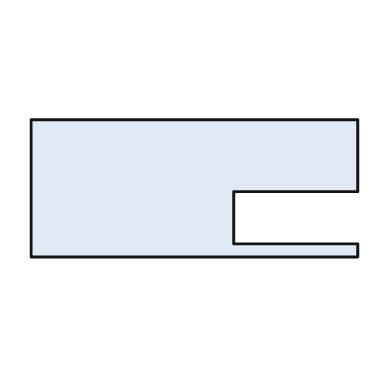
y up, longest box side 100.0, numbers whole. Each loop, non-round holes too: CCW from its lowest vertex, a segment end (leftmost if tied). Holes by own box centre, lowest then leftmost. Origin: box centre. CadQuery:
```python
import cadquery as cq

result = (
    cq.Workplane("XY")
    .moveTo(-50.0, -21.0)
    .lineTo(50.0, -21.0)
    .lineTo(50.0, -17.0)
    .lineTo(12.0, -17.0)
    .lineTo(12.0, -1.0)
    .lineTo(50.0, -1.0)
    .lineTo(50.0, 21.0)
    .lineTo(-50.0, 21.0)
    .close()
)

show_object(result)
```